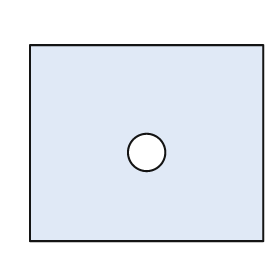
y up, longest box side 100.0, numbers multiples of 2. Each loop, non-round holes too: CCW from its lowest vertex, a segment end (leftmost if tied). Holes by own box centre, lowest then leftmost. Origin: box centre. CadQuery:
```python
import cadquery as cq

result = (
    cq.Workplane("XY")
    .moveTo(-50.0, -42.0)
    .lineTo(50.0, -42.0)
    .lineTo(50.0, 42.0)
    .lineTo(-50.0, 42.0)
    .close()
    .moveTo(0.0, -4.0)
    .circle(8.0)
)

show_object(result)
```